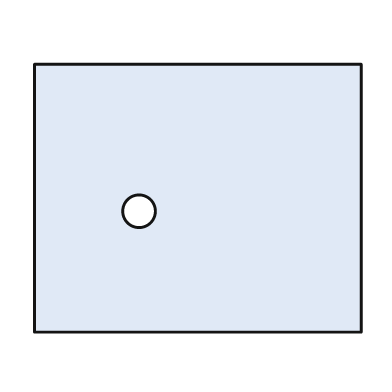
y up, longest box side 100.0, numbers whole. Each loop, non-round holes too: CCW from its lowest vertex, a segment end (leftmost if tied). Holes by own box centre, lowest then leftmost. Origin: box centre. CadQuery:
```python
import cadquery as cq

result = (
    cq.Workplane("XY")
    .moveTo(-50.0, -41.0)
    .lineTo(50.0, -41.0)
    .lineTo(50.0, 41.0)
    .lineTo(-50.0, 41.0)
    .close()
    .moveTo(-18.0, -4.0)
    .circle(5.0)
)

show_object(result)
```